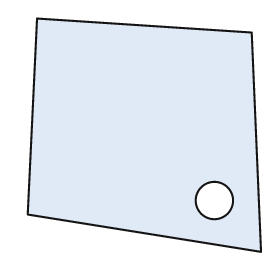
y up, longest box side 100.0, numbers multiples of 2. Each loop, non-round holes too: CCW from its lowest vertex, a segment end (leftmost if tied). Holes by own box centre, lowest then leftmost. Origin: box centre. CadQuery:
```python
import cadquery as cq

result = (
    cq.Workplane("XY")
    .moveTo(50.0, -50.0)
    .lineTo(46.0, 44.0)
    .lineTo(-46.0, 50.0)
    .lineTo(-50.0, -34.0)
    .close()
    .moveTo(30.0, -28.0)
    .circle(8.0)
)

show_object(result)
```